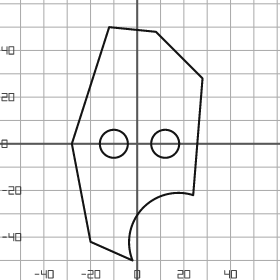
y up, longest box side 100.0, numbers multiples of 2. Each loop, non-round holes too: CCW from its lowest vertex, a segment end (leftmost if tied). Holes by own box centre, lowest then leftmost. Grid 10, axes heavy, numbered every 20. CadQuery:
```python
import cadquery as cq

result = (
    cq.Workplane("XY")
    .moveTo(-2.0, -50.0)
    .threePointArc((2.0, -28.0), (24.0, -22.0))
    .lineTo(28.0, 28.0)
    .lineTo(8.0, 48.0)
    .lineTo(-12.0, 50.0)
    .lineTo(-28.0, 0.0)
    .lineTo(-20.0, -42.0)
    .close()
    .moveTo(-10.0, 0.0)
    .circle(6.0)
    .moveTo(12.0, 0.0)
    .circle(6.0)
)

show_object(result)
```